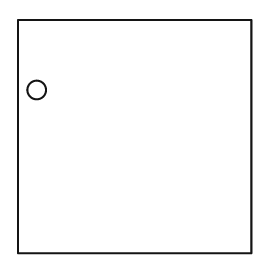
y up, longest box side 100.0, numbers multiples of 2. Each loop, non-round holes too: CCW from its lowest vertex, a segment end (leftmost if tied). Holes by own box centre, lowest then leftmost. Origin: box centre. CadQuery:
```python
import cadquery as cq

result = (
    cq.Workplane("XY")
    .moveTo(-50.0, -50.0)
    .lineTo(50.0, -50.0)
    .lineTo(50.0, 50.0)
    .lineTo(-50.0, 50.0)
    .close()
    .moveTo(-42.0, 20.0)
    .circle(4.0)
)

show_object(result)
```